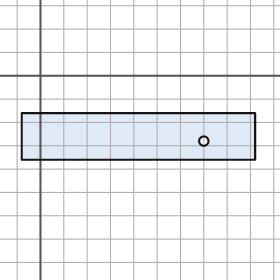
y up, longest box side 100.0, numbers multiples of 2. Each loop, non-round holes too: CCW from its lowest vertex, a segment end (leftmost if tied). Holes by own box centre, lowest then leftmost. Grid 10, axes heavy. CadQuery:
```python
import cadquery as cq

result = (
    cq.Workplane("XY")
    .moveTo(-8.0, -36.0)
    .lineTo(92.0, -36.0)
    .lineTo(92.0, -16.0)
    .lineTo(-8.0, -16.0)
    .close()
    .moveTo(70.0, -28.0)
    .circle(2.0)
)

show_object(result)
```